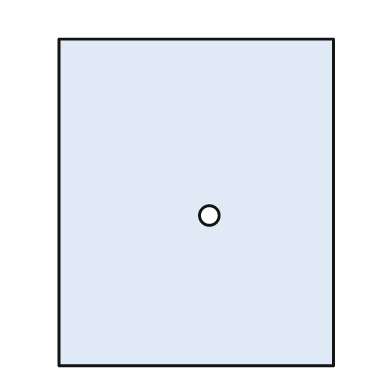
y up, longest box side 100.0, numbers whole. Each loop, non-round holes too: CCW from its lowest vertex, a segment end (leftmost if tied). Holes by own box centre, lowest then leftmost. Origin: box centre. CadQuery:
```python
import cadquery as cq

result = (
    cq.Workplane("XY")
    .moveTo(-42.0, -50.0)
    .lineTo(42.0, -50.0)
    .lineTo(42.0, 50.0)
    .lineTo(-42.0, 50.0)
    .close()
    .moveTo(4.0, -4.0)
    .circle(3.0)
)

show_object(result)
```